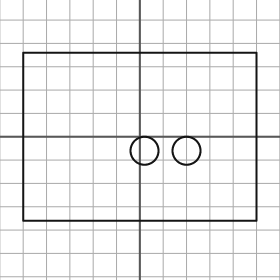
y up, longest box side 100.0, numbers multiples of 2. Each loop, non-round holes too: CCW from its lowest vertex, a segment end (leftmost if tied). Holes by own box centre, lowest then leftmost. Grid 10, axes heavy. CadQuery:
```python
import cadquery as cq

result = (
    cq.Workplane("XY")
    .moveTo(-50.0, -36.0)
    .lineTo(50.0, -36.0)
    .lineTo(50.0, 36.0)
    .lineTo(-50.0, 36.0)
    .close()
    .moveTo(2.0, -6.0)
    .circle(6.0)
    .moveTo(20.0, -6.0)
    .circle(6.0)
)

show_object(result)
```